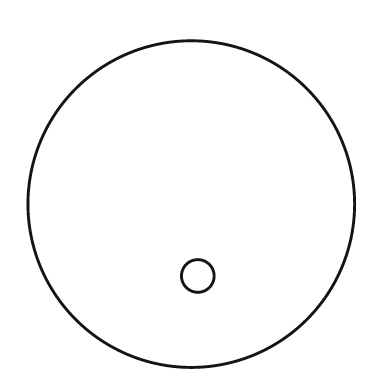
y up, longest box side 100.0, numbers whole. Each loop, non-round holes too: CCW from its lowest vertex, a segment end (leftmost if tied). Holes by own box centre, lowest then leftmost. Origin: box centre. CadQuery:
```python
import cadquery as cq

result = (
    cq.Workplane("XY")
    .moveTo(0.0, 0.0)
    .circle(50.0)
    .moveTo(2.0, -22.0)
    .circle(5.0)
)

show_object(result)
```